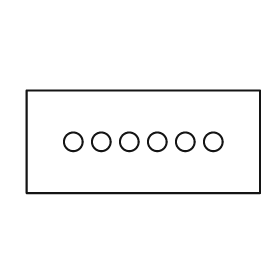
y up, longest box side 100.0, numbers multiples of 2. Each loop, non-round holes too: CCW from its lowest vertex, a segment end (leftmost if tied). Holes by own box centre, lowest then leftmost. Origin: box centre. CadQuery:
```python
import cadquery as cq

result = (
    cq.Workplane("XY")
    .moveTo(-50.0, -22.0)
    .lineTo(50.0, -22.0)
    .lineTo(50.0, 22.0)
    .lineTo(-50.0, 22.0)
    .close()
    .moveTo(-30.0, 0.0)
    .circle(4.0)
    .moveTo(-18.0, 0.0)
    .circle(4.0)
    .moveTo(-6.0, 0.0)
    .circle(4.0)
    .moveTo(6.0, 0.0)
    .circle(4.0)
    .moveTo(18.0, 0.0)
    .circle(4.0)
    .moveTo(30.0, 0.0)
    .circle(4.0)
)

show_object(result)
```